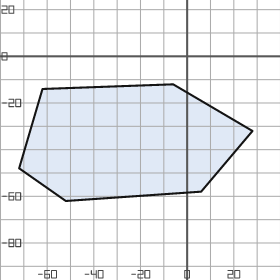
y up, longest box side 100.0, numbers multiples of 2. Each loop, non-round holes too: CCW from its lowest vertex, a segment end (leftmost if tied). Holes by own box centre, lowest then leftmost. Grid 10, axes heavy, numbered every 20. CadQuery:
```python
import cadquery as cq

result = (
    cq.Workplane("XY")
    .moveTo(-52.0, -62.0)
    .lineTo(6.0, -58.0)
    .lineTo(28.0, -32.0)
    .lineTo(-6.0, -12.0)
    .lineTo(-62.0, -14.0)
    .lineTo(-72.0, -48.0)
    .close()
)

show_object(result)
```